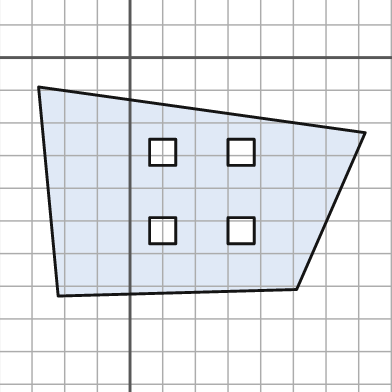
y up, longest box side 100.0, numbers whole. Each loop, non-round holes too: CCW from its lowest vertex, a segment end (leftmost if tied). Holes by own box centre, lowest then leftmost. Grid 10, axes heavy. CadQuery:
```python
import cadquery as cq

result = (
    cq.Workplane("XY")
    .moveTo(-22.0, -73.0)
    .lineTo(51.0, -71.0)
    .lineTo(72.0, -23.0)
    .lineTo(-28.0, -9.0)
    .close()
    .moveTo(6.0, -57.0)
    .lineTo(14.0, -57.0)
    .lineTo(14.0, -49.0)
    .lineTo(6.0, -49.0)
    .close()
    .moveTo(30.0, -57.0)
    .lineTo(38.0, -57.0)
    .lineTo(38.0, -49.0)
    .lineTo(30.0, -49.0)
    .close()
    .moveTo(6.0, -33.0)
    .lineTo(14.0, -33.0)
    .lineTo(14.0, -25.0)
    .lineTo(6.0, -25.0)
    .close()
    .moveTo(30.0, -33.0)
    .lineTo(38.0, -33.0)
    .lineTo(38.0, -25.0)
    .lineTo(30.0, -25.0)
    .close()
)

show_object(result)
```